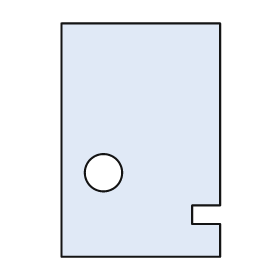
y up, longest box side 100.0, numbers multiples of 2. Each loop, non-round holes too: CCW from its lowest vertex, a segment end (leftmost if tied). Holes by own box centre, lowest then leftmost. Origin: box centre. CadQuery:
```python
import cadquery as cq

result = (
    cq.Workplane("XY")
    .moveTo(-34.0, -50.0)
    .lineTo(34.0, -50.0)
    .lineTo(34.0, -36.0)
    .lineTo(22.0, -36.0)
    .lineTo(22.0, -28.0)
    .lineTo(34.0, -28.0)
    .lineTo(34.0, 50.0)
    .lineTo(-34.0, 50.0)
    .close()
    .moveTo(-16.0, -14.0)
    .circle(8.0)
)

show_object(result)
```